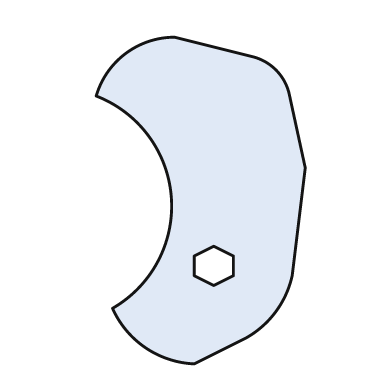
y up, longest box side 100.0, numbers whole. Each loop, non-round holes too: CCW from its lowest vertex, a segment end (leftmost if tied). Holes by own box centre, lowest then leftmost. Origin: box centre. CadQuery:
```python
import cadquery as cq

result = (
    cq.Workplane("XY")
    .moveTo(-2.0, -50.0)
    .lineTo(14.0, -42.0)
    .threePointArc((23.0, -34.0), (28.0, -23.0))
    .lineTo(32.0, 10.0)
    .lineTo(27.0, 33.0)
    .threePointArc((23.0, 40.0), (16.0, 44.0))
    .lineTo(-8.0, 50.0)
    .threePointArc((-23.0, 45.0), (-32.0, 32.0))
    .threePointArc((-9.0, 1.0), (-27.0, -33.0))
    .threePointArc((-17.0, -45.0), (-2.0, -50.0))
    .close()
    .moveTo(4.0, -26.0)
    .lineTo(10.0, -23.0)
    .lineTo(10.0, -17.0)
    .lineTo(4.0, -14.0)
    .lineTo(-2.0, -17.0)
    .lineTo(-2.0, -23.0)
    .close()
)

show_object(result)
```